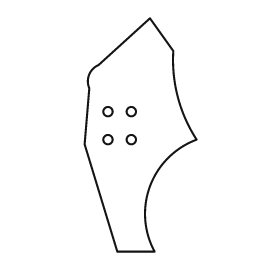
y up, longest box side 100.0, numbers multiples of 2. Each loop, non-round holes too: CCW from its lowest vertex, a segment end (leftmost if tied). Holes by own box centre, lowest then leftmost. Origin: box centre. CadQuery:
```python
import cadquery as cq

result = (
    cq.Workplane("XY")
    .moveTo(-10.0, -50.0)
    .lineTo(6.0, -50.0)
    .threePointArc((4.0, -22.0), (24.0, -2.0))
    .threePointArc((16.0, 16.0), (14.0, 36.0))
    .lineTo(4.0, 50.0)
    .lineTo(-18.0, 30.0)
    .threePointArc((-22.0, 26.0), (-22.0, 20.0))
    .lineTo(-24.0, -4.0)
    .close()
    .moveTo(-14.0, -2.0)
    .circle(2.0)
    .moveTo(-4.0, -2.0)
    .circle(2.0)
    .moveTo(-14.0, 10.0)
    .circle(2.0)
    .moveTo(-4.0, 10.0)
    .circle(2.0)
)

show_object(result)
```